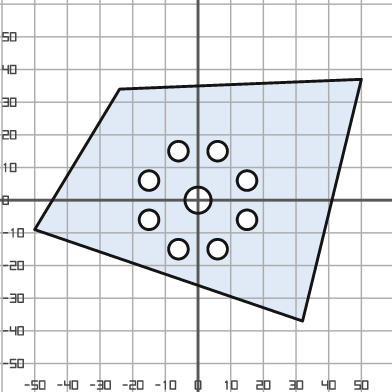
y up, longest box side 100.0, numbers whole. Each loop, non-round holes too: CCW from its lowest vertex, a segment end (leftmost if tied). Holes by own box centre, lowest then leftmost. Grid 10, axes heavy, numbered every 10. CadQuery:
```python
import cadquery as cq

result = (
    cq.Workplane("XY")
    .moveTo(32.0, -37.0)
    .lineTo(50.0, 37.0)
    .lineTo(-24.0, 34.0)
    .lineTo(-50.0, -9.0)
    .close()
    .moveTo(-6.0, -15.0)
    .circle(3.0)
    .moveTo(6.0, -15.0)
    .circle(3.0)
    .moveTo(-15.0, -6.0)
    .circle(3.0)
    .moveTo(15.0, -6.0)
    .circle(3.0)
    .moveTo(0.0, 0.0)
    .circle(4.0)
    .moveTo(-15.0, 6.0)
    .circle(3.0)
    .moveTo(15.0, 6.0)
    .circle(3.0)
    .moveTo(-6.0, 15.0)
    .circle(3.0)
    .moveTo(6.0, 15.0)
    .circle(3.0)
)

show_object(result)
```